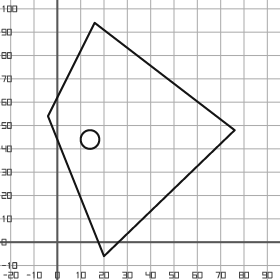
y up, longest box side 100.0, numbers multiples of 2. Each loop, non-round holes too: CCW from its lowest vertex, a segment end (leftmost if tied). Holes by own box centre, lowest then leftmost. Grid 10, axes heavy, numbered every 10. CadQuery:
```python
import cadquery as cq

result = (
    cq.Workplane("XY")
    .moveTo(20.0, -6.0)
    .lineTo(76.0, 48.0)
    .lineTo(16.0, 94.0)
    .lineTo(-4.0, 54.0)
    .close()
    .moveTo(14.0, 44.0)
    .circle(4.0)
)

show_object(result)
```